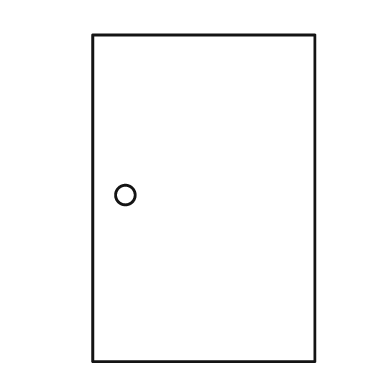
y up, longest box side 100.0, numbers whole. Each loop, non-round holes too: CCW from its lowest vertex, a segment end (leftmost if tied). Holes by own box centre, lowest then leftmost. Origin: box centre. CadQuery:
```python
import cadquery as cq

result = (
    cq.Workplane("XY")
    .moveTo(-34.0, -50.0)
    .lineTo(34.0, -50.0)
    .lineTo(34.0, 50.0)
    .lineTo(-34.0, 50.0)
    .close()
    .moveTo(-24.0, 1.0)
    .circle(3.0)
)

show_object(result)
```